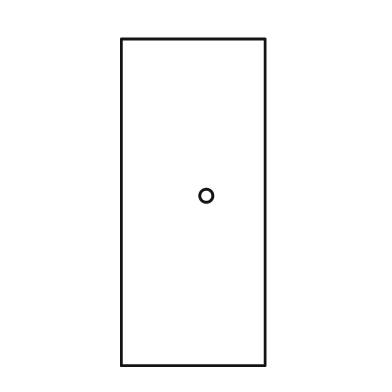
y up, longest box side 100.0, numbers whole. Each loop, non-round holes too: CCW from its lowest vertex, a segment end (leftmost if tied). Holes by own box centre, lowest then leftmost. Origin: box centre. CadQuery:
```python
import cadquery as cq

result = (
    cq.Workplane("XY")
    .moveTo(-22.0, -50.0)
    .lineTo(22.0, -50.0)
    .lineTo(22.0, 50.0)
    .lineTo(-22.0, 50.0)
    .close()
    .moveTo(4.0, 2.0)
    .circle(2.0)
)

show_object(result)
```